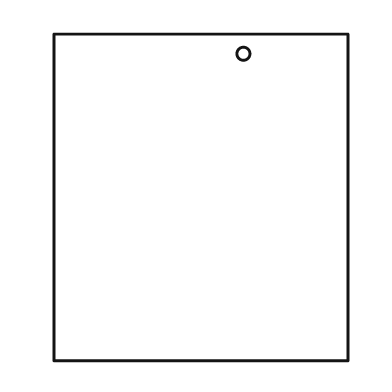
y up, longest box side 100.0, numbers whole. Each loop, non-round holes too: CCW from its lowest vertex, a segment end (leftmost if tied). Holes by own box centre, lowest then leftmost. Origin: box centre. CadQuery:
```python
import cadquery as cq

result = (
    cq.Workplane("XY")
    .moveTo(-45.0, -50.0)
    .lineTo(45.0, -50.0)
    .lineTo(45.0, 50.0)
    .lineTo(-45.0, 50.0)
    .close()
    .moveTo(13.0, 44.0)
    .circle(2.0)
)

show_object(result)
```